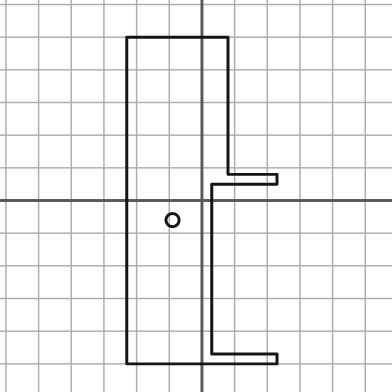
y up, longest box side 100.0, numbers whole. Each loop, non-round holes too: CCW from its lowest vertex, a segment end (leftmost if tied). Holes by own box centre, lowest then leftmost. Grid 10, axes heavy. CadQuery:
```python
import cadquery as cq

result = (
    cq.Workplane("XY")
    .moveTo(-23.0, -50.0)
    .lineTo(23.0, -50.0)
    .lineTo(23.0, -47.0)
    .lineTo(3.0, -47.0)
    .lineTo(3.0, 5.0)
    .lineTo(23.0, 5.0)
    .lineTo(23.0, 8.0)
    .lineTo(8.0, 8.0)
    .lineTo(8.0, 50.0)
    .lineTo(-23.0, 50.0)
    .close()
    .moveTo(-9.0, -6.0)
    .circle(2.0)
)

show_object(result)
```